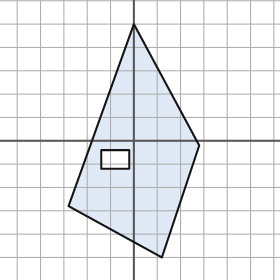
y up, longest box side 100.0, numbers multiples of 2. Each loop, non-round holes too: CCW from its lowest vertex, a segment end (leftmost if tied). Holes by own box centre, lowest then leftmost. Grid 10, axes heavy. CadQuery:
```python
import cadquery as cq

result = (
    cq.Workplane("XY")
    .moveTo(12.0, -50.0)
    .lineTo(28.0, -2.0)
    .lineTo(0.0, 50.0)
    .lineTo(-28.0, -28.0)
    .close()
    .moveTo(-14.0, -12.0)
    .lineTo(-2.0, -12.0)
    .lineTo(-2.0, -4.0)
    .lineTo(-14.0, -4.0)
    .close()
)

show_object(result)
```